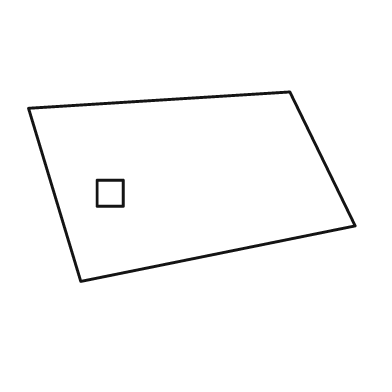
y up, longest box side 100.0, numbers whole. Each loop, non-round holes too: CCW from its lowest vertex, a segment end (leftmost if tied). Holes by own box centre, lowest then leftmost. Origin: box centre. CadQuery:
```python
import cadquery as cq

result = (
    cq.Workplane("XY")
    .moveTo(-34.0, -29.0)
    .lineTo(50.0, -12.0)
    .lineTo(30.0, 29.0)
    .lineTo(-50.0, 24.0)
    .close()
    .moveTo(-29.0, -6.0)
    .lineTo(-21.0, -6.0)
    .lineTo(-21.0, 2.0)
    .lineTo(-29.0, 2.0)
    .close()
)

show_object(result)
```